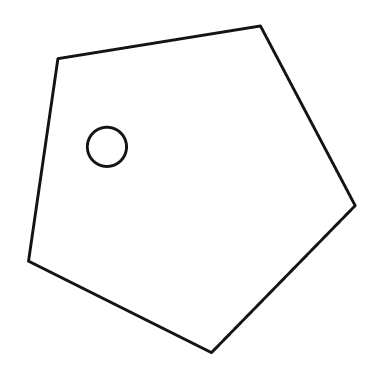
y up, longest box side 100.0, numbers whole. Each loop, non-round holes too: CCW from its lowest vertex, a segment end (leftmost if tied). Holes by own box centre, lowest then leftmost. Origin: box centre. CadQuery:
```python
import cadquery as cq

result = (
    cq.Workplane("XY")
    .moveTo(6.0, -50.0)
    .lineTo(50.0, -5.0)
    .lineTo(21.0, 50.0)
    .lineTo(-41.0, 40.0)
    .lineTo(-50.0, -22.0)
    .close()
    .moveTo(-26.0, 13.0)
    .circle(6.0)
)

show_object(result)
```